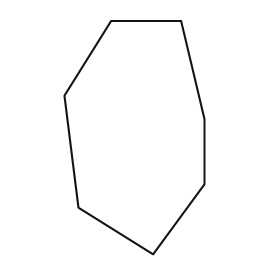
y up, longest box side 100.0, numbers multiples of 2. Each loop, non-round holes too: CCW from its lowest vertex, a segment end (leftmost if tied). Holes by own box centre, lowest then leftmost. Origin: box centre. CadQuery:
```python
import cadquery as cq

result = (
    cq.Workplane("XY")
    .moveTo(8.0, -50.0)
    .lineTo(30.0, -20.0)
    .lineTo(30.0, 8.0)
    .lineTo(20.0, 50.0)
    .lineTo(-10.0, 50.0)
    .lineTo(-30.0, 18.0)
    .lineTo(-24.0, -30.0)
    .close()
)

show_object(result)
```